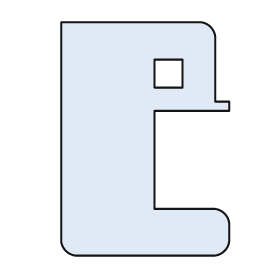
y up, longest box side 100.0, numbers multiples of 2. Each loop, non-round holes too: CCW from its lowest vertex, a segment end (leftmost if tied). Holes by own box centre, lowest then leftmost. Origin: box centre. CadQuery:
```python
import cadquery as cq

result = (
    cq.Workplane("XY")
    .moveTo(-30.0, -50.0)
    .lineTo(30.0, -50.0)
    .threePointArc((34.0, -48.0), (36.0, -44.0))
    .lineTo(36.0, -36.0)
    .threePointArc((34.0, -32.0), (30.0, -30.0))
    .lineTo(4.0, -30.0)
    .lineTo(4.0, 12.0)
    .lineTo(36.0, 12.0)
    .lineTo(36.0, 16.0)
    .lineTo(30.0, 16.0)
    .lineTo(30.0, 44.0)
    .threePointArc((28.0, 48.0), (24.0, 50.0))
    .lineTo(-36.0, 50.0)
    .lineTo(-36.0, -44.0)
    .threePointArc((-34.0, -48.0), (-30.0, -50.0))
    .close()
    .moveTo(4.0, 22.0)
    .lineTo(16.0, 22.0)
    .lineTo(16.0, 34.0)
    .lineTo(4.0, 34.0)
    .close()
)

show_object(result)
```